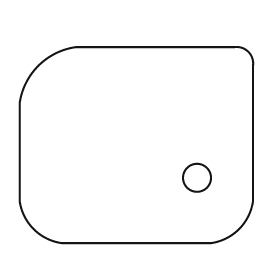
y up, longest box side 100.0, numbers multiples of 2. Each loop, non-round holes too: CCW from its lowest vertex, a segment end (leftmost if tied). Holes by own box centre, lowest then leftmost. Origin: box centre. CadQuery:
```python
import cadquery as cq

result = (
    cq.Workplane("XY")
    .moveTo(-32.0, -42.0)
    .lineTo(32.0, -42.0)
    .threePointArc((44.0, -36.0), (50.0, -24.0))
    .lineTo(50.0, 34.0)
    .threePointArc((48.0, 40.0), (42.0, 42.0))
    .lineTo(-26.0, 42.0)
    .threePointArc((-42.0, 34.0), (-50.0, 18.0))
    .lineTo(-50.0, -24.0)
    .threePointArc((-44.0, -36.0), (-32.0, -42.0))
    .close()
    .moveTo(26.0, -14.0)
    .circle(6.0)
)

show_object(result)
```